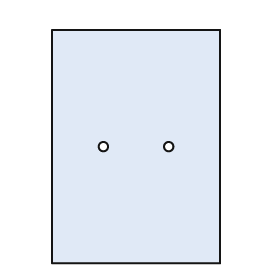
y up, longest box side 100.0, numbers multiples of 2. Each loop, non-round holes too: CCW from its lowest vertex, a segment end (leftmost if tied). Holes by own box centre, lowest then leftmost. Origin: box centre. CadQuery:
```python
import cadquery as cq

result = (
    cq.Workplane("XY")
    .moveTo(-36.0, -50.0)
    .lineTo(36.0, -50.0)
    .lineTo(36.0, 50.0)
    .lineTo(-36.0, 50.0)
    .close()
    .moveTo(-14.0, 0.0)
    .circle(2.0)
    .moveTo(14.0, 0.0)
    .circle(2.0)
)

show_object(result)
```